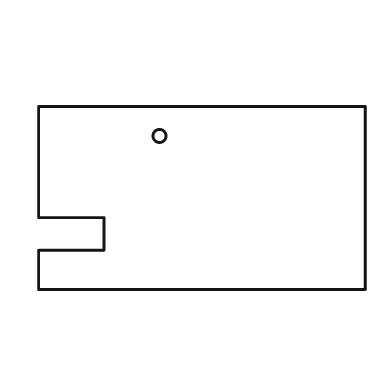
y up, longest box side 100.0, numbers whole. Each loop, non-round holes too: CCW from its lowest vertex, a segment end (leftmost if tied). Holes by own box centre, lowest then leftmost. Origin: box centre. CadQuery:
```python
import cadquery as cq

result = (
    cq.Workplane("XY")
    .moveTo(-50.0, -28.0)
    .lineTo(50.0, -28.0)
    .lineTo(50.0, 28.0)
    .lineTo(-50.0, 28.0)
    .lineTo(-50.0, -6.0)
    .lineTo(-30.0, -6.0)
    .lineTo(-30.0, -16.0)
    .lineTo(-50.0, -16.0)
    .close()
    .moveTo(-13.0, 19.0)
    .circle(2.0)
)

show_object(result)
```